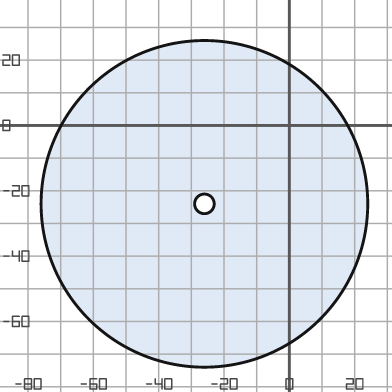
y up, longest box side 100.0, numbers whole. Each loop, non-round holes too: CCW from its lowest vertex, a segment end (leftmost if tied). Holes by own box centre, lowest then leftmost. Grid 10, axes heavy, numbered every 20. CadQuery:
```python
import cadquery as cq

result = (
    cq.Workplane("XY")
    .moveTo(-26.0, -24.0)
    .circle(50.0)
    .moveTo(-26.0, -24.0)
    .circle(3.0)
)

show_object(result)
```